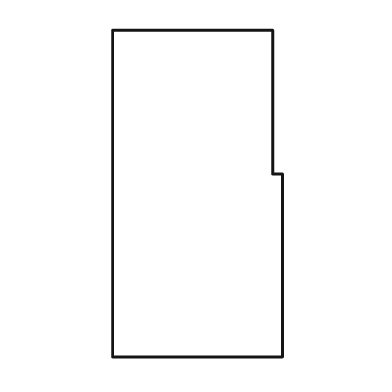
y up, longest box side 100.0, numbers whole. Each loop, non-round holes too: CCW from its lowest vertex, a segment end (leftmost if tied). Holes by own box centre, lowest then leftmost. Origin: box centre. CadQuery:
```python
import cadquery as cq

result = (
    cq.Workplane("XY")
    .moveTo(-26.0, -50.0)
    .lineTo(26.0, -50.0)
    .lineTo(26.0, 6.0)
    .lineTo(23.0, 6.0)
    .lineTo(23.0, 50.0)
    .lineTo(-26.0, 50.0)
    .close()
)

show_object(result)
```